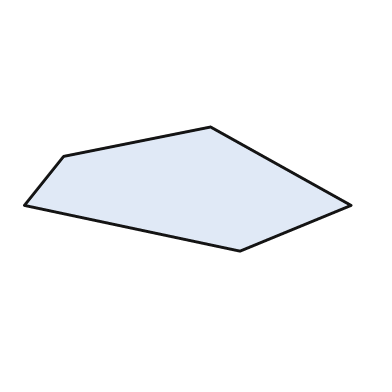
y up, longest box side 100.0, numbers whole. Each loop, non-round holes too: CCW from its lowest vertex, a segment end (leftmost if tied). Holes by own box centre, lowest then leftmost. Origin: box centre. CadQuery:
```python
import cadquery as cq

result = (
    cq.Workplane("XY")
    .moveTo(16.0, -19.0)
    .lineTo(50.0, -5.0)
    .lineTo(7.0, 19.0)
    .lineTo(-38.0, 10.0)
    .lineTo(-50.0, -5.0)
    .close()
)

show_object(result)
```